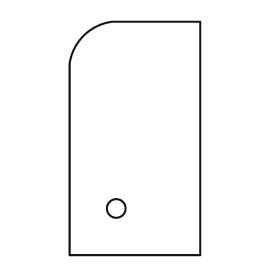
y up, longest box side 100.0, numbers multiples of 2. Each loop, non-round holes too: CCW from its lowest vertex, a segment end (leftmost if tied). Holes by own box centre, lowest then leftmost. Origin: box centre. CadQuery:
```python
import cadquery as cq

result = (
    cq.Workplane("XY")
    .moveTo(-28.0, -50.0)
    .lineTo(28.0, -50.0)
    .lineTo(28.0, 50.0)
    .lineTo(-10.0, 50.0)
    .threePointArc((-22.0, 44.0), (-28.0, 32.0))
    .close()
    .moveTo(-8.0, -30.0)
    .circle(4.0)
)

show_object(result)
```